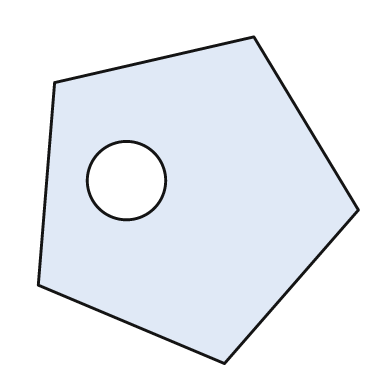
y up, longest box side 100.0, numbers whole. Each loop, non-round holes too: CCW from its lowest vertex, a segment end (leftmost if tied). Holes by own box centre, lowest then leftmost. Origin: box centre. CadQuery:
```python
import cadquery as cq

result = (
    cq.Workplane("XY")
    .moveTo(8.0, -50.0)
    .lineTo(49.0, -3.0)
    .lineTo(17.0, 50.0)
    .lineTo(-44.0, 36.0)
    .lineTo(-49.0, -26.0)
    .close()
    .moveTo(-22.0, 6.0)
    .circle(12.0)
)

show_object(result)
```